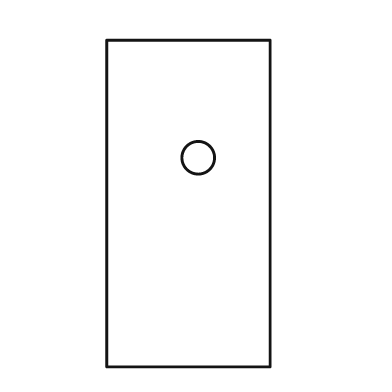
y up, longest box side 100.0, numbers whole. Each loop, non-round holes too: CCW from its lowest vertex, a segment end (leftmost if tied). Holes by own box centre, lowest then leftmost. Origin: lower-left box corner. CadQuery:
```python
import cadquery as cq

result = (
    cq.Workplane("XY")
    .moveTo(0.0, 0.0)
    .lineTo(50.0, 0.0)
    .lineTo(50.0, 100.0)
    .lineTo(0.0, 100.0)
    .close()
    .moveTo(28.0, 64.0)
    .circle(5.0)
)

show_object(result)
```